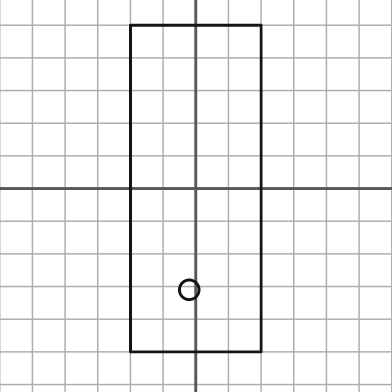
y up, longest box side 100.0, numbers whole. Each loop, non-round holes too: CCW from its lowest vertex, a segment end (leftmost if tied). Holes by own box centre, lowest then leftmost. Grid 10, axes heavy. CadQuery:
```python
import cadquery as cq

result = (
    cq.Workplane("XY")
    .moveTo(-20.0, -50.0)
    .lineTo(20.0, -50.0)
    .lineTo(20.0, 50.0)
    .lineTo(-20.0, 50.0)
    .close()
    .moveTo(-2.0, -31.0)
    .circle(3.0)
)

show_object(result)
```